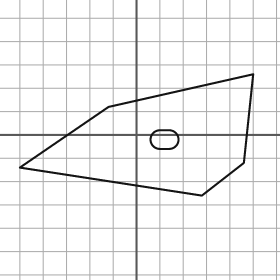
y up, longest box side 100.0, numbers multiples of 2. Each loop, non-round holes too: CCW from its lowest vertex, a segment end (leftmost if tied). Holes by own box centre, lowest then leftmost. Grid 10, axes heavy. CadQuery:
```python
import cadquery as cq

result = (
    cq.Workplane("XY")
    .moveTo(28.0, -26.0)
    .lineTo(46.0, -12.0)
    .lineTo(50.0, 26.0)
    .lineTo(-12.0, 12.0)
    .lineTo(-50.0, -14.0)
    .close()
    .moveTo(10.0, -6.0)
    .lineTo(14.0, -6.0)
    .threePointArc((18.0, -2.0), (14.0, 2.0))
    .lineTo(10.0, 2.0)
    .threePointArc((6.0, -2.0), (10.0, -6.0))
    .close()
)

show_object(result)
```